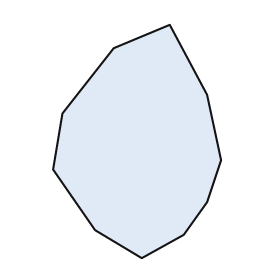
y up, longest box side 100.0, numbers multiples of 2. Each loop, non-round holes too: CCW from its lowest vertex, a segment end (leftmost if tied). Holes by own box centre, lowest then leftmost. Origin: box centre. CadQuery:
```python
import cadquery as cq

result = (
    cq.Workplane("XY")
    .moveTo(2.0, -50.0)
    .lineTo(20.0, -40.0)
    .lineTo(30.0, -26.0)
    .lineTo(36.0, -8.0)
    .lineTo(30.0, 20.0)
    .lineTo(14.0, 50.0)
    .lineTo(-10.0, 40.0)
    .lineTo(-32.0, 12.0)
    .lineTo(-36.0, -12.0)
    .lineTo(-18.0, -38.0)
    .close()
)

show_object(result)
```